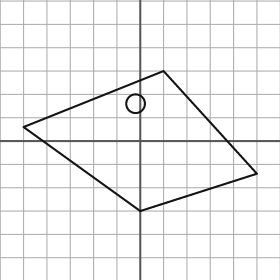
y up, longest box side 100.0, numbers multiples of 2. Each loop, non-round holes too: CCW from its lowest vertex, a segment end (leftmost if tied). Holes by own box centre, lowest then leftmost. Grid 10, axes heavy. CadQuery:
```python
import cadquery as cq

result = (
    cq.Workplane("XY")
    .moveTo(0.0, -30.0)
    .lineTo(50.0, -14.0)
    .lineTo(10.0, 30.0)
    .lineTo(-50.0, 6.0)
    .close()
    .moveTo(-2.0, 16.0)
    .circle(4.0)
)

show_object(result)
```